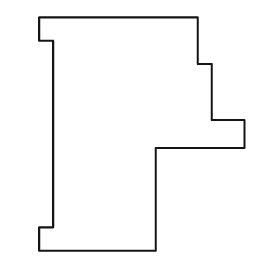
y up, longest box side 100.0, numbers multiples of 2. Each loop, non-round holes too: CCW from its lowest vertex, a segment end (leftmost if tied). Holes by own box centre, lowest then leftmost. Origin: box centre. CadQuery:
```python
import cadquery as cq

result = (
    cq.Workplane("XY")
    .moveTo(-44.0, -50.0)
    .lineTo(6.0, -50.0)
    .lineTo(6.0, -6.0)
    .lineTo(44.0, -6.0)
    .lineTo(44.0, 6.0)
    .lineTo(30.0, 6.0)
    .lineTo(30.0, 30.0)
    .lineTo(24.0, 30.0)
    .lineTo(24.0, 50.0)
    .lineTo(-44.0, 50.0)
    .lineTo(-44.0, 40.0)
    .lineTo(-38.0, 40.0)
    .lineTo(-38.0, -40.0)
    .lineTo(-44.0, -40.0)
    .close()
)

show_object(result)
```